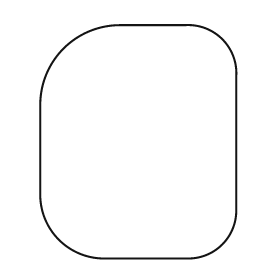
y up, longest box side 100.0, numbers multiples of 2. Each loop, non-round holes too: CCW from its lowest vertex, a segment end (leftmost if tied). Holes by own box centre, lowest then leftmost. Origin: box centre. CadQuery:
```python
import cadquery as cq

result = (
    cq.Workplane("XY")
    .moveTo(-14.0, -50.0)
    .lineTo(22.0, -50.0)
    .threePointArc((36.0, -44.0), (42.0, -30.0))
    .lineTo(42.0, 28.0)
    .threePointArc((36.0, 44.0), (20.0, 50.0))
    .lineTo(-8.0, 50.0)
    .threePointArc((-32.0, 40.0), (-42.0, 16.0))
    .lineTo(-42.0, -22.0)
    .threePointArc((-34.0, -42.0), (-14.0, -50.0))
    .close()
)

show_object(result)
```